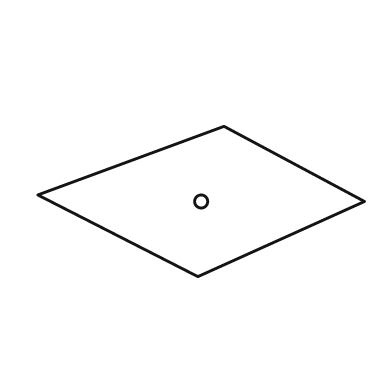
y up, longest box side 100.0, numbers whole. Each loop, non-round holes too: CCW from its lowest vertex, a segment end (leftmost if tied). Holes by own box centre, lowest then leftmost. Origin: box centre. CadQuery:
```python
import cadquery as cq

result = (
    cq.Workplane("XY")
    .moveTo(-1.0, -23.0)
    .lineTo(50.0, 0.0)
    .lineTo(7.0, 23.0)
    .lineTo(-50.0, 2.0)
    .close()
    .moveTo(0.0, 0.0)
    .circle(2.0)
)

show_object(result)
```